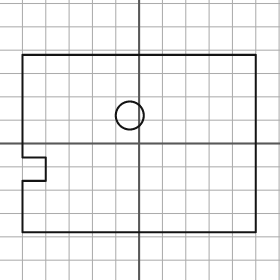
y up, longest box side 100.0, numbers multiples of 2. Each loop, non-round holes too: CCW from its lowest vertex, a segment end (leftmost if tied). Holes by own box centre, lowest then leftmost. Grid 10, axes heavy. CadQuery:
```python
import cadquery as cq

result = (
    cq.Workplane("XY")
    .moveTo(-50.0, -38.0)
    .lineTo(50.0, -38.0)
    .lineTo(50.0, 38.0)
    .lineTo(-50.0, 38.0)
    .lineTo(-50.0, -6.0)
    .lineTo(-40.0, -6.0)
    .lineTo(-40.0, -16.0)
    .lineTo(-50.0, -16.0)
    .close()
    .moveTo(-4.0, 12.0)
    .circle(6.0)
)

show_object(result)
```